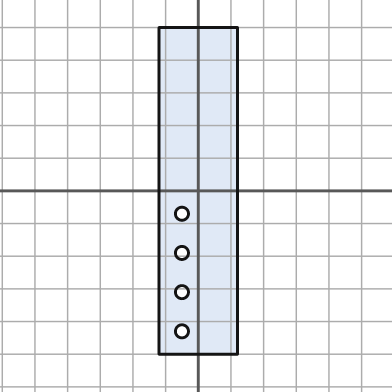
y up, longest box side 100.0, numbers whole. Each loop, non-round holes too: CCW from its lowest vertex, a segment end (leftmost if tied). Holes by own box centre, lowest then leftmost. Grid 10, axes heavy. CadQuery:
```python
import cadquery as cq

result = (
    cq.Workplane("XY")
    .moveTo(-12.0, -50.0)
    .lineTo(12.0, -50.0)
    .lineTo(12.0, 50.0)
    .lineTo(-12.0, 50.0)
    .close()
    .moveTo(-5.0, -43.0)
    .circle(2.0)
    .moveTo(-5.0, -31.0)
    .circle(2.0)
    .moveTo(-5.0, -19.0)
    .circle(2.0)
    .moveTo(-5.0, -7.0)
    .circle(2.0)
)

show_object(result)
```